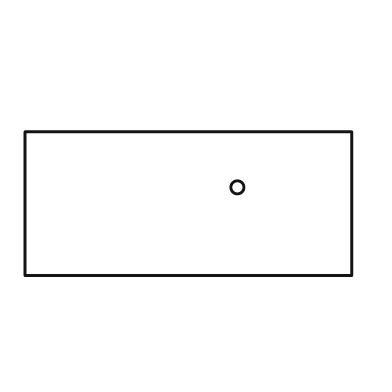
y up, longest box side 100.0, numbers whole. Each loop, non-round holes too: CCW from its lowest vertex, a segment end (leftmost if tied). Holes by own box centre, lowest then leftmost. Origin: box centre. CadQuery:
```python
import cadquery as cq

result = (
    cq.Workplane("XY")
    .moveTo(-50.0, -22.0)
    .lineTo(50.0, -22.0)
    .lineTo(50.0, 22.0)
    .lineTo(-50.0, 22.0)
    .close()
    .moveTo(15.0, 5.0)
    .circle(2.0)
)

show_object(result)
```